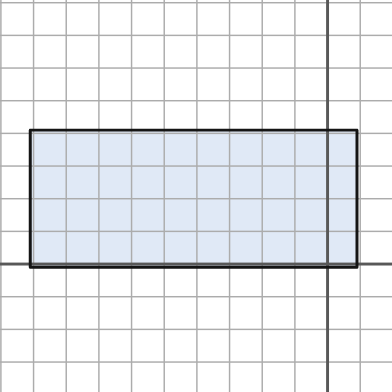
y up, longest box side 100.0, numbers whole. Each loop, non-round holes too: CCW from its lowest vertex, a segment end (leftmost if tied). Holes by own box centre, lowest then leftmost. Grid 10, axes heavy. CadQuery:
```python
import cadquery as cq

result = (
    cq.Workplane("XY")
    .moveTo(-91.0, -1.0)
    .lineTo(9.0, -1.0)
    .lineTo(9.0, 41.0)
    .lineTo(-91.0, 41.0)
    .close()
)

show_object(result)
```